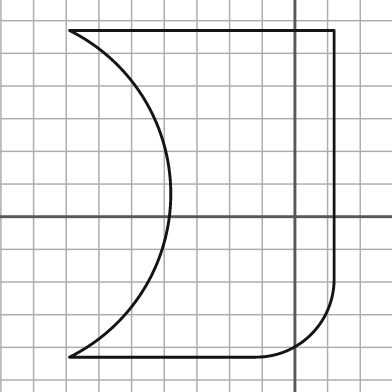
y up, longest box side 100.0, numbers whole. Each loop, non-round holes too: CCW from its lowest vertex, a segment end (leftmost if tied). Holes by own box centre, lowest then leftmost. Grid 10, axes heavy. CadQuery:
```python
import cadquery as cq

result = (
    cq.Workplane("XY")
    .moveTo(-69.0, -43.0)
    .lineTo(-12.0, -43.0)
    .threePointArc((5.0, -36.0), (12.0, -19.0))
    .lineTo(12.0, 57.0)
    .lineTo(-69.0, 57.0)
    .threePointArc((-38.0, 7.0), (-69.0, -43.0))
    .close()
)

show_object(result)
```